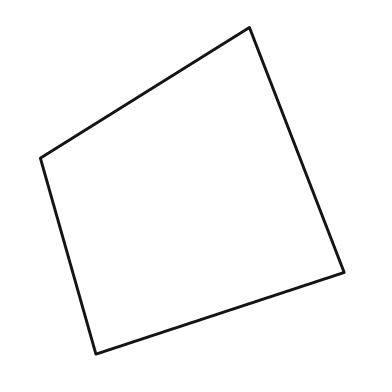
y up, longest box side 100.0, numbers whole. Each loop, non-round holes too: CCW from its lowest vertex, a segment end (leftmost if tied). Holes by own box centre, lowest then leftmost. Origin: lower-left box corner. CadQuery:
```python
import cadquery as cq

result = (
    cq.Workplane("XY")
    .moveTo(17.0, 0.0)
    .lineTo(93.0, 25.0)
    .lineTo(64.0, 100.0)
    .lineTo(0.0, 60.0)
    .close()
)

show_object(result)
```